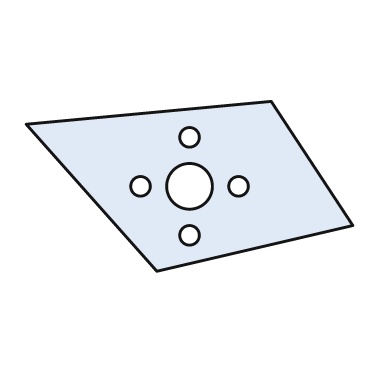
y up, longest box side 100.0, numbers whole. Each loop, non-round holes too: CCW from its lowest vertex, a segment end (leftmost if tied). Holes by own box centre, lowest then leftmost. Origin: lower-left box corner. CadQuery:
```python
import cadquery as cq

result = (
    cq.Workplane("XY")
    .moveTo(40.0, 0.0)
    .lineTo(100.0, 14.0)
    .lineTo(75.0, 52.0)
    .lineTo(0.0, 45.0)
    .close()
    .moveTo(50.0, 11.0)
    .circle(3.0)
    .moveTo(35.0, 26.0)
    .circle(3.0)
    .moveTo(50.0, 26.0)
    .circle(7.0)
    .moveTo(65.0, 26.0)
    .circle(3.0)
    .moveTo(50.0, 41.0)
    .circle(3.0)
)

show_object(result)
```